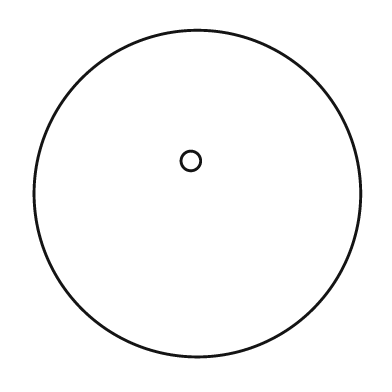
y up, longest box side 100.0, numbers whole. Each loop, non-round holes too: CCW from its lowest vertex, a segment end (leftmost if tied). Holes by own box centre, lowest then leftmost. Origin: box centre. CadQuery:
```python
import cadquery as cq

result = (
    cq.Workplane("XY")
    .moveTo(0.0, 0.0)
    .circle(50.0)
    .moveTo(-2.0, 10.0)
    .circle(3.0)
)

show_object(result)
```